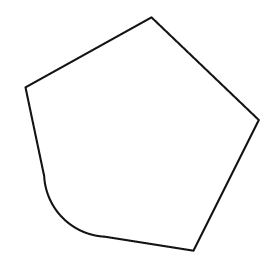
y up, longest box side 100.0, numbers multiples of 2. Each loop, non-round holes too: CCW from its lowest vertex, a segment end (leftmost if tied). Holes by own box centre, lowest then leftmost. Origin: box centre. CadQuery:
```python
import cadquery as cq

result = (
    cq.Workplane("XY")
    .moveTo(22.0, -50.0)
    .lineTo(50.0, 6.0)
    .lineTo(4.0, 50.0)
    .lineTo(-50.0, 20.0)
    .lineTo(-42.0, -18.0)
    .threePointArc((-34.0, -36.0), (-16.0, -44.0))
    .close()
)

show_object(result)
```